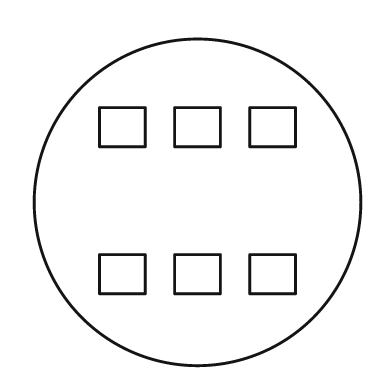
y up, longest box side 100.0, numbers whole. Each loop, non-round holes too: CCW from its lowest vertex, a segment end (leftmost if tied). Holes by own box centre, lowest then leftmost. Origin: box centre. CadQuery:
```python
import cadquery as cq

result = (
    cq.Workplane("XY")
    .moveTo(0.0, 0.0)
    .circle(50.0)
    .moveTo(-30.0, -28.0)
    .lineTo(-16.0, -28.0)
    .lineTo(-16.0, -16.0)
    .lineTo(-30.0, -16.0)
    .close()
    .moveTo(-7.0, -28.0)
    .lineTo(7.0, -28.0)
    .lineTo(7.0, -16.0)
    .lineTo(-7.0, -16.0)
    .close()
    .moveTo(16.0, -28.0)
    .lineTo(30.0, -28.0)
    .lineTo(30.0, -16.0)
    .lineTo(16.0, -16.0)
    .close()
    .moveTo(-30.0, 17.0)
    .lineTo(-16.0, 17.0)
    .lineTo(-16.0, 29.0)
    .lineTo(-30.0, 29.0)
    .close()
    .moveTo(-7.0, 17.0)
    .lineTo(7.0, 17.0)
    .lineTo(7.0, 29.0)
    .lineTo(-7.0, 29.0)
    .close()
    .moveTo(16.0, 17.0)
    .lineTo(30.0, 17.0)
    .lineTo(30.0, 29.0)
    .lineTo(16.0, 29.0)
    .close()
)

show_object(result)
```